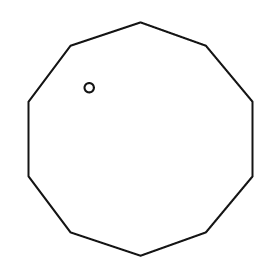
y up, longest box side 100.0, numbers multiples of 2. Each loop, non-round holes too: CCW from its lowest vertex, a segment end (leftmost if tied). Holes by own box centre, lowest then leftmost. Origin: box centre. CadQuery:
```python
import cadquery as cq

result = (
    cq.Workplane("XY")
    .moveTo(0.0, -50.0)
    .lineTo(28.0, -40.0)
    .lineTo(48.0, -16.0)
    .lineTo(48.0, 16.0)
    .lineTo(28.0, 40.0)
    .lineTo(0.0, 50.0)
    .lineTo(-30.0, 40.0)
    .lineTo(-48.0, 16.0)
    .lineTo(-48.0, -16.0)
    .lineTo(-30.0, -40.0)
    .close()
    .moveTo(-22.0, 22.0)
    .circle(2.0)
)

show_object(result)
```